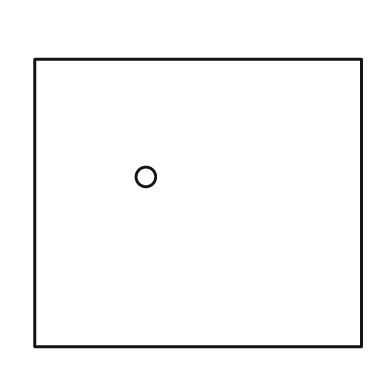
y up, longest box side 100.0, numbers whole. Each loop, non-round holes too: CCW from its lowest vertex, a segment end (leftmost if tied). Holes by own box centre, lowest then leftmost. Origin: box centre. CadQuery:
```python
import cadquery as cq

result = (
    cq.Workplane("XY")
    .moveTo(-50.0, -44.0)
    .lineTo(50.0, -44.0)
    .lineTo(50.0, 44.0)
    .lineTo(-50.0, 44.0)
    .close()
    .moveTo(-16.0, 8.0)
    .circle(3.0)
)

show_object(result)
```